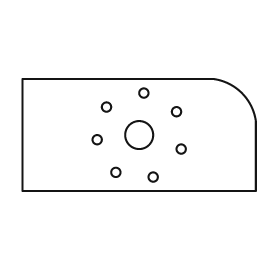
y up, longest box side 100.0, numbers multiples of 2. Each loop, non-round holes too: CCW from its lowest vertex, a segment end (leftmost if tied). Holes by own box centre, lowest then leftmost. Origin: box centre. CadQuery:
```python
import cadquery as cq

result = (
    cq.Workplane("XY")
    .moveTo(-50.0, -24.0)
    .lineTo(50.0, -24.0)
    .lineTo(50.0, 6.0)
    .threePointArc((44.0, 18.0), (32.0, 24.0))
    .lineTo(-50.0, 24.0)
    .close()
    .moveTo(6.0, -18.0)
    .circle(2.0)
    .moveTo(-10.0, -16.0)
    .circle(2.0)
    .moveTo(18.0, -6.0)
    .circle(2.0)
    .moveTo(-18.0, -2.0)
    .circle(2.0)
    .moveTo(0.0, 0.0)
    .circle(6.0)
    .moveTo(16.0, 10.0)
    .circle(2.0)
    .moveTo(-14.0, 12.0)
    .circle(2.0)
    .moveTo(2.0, 18.0)
    .circle(2.0)
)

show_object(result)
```